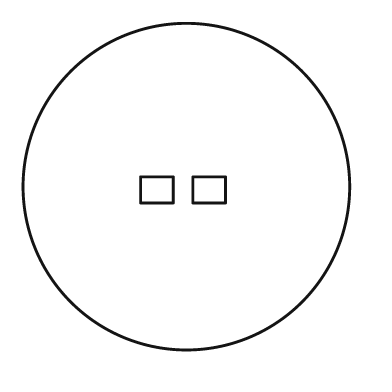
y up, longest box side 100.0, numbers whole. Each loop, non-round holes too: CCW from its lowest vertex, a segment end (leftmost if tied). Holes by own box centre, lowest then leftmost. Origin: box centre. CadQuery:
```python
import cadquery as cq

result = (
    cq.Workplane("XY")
    .moveTo(0.0, 0.0)
    .circle(50.0)
    .moveTo(-14.0, -5.0)
    .lineTo(-4.0, -5.0)
    .lineTo(-4.0, 3.0)
    .lineTo(-14.0, 3.0)
    .close()
    .moveTo(2.0, -5.0)
    .lineTo(12.0, -5.0)
    .lineTo(12.0, 3.0)
    .lineTo(2.0, 3.0)
    .close()
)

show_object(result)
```